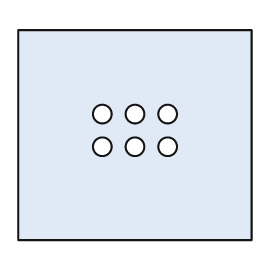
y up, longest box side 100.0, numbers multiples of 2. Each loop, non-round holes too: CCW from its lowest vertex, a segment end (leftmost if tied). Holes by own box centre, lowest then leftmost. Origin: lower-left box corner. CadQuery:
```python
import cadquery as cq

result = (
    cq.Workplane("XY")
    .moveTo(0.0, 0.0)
    .lineTo(100.0, 0.0)
    .lineTo(100.0, 90.0)
    .lineTo(0.0, 90.0)
    .close()
    .moveTo(36.0, 40.0)
    .circle(4.0)
    .moveTo(50.0, 40.0)
    .circle(4.0)
    .moveTo(64.0, 40.0)
    .circle(4.0)
    .moveTo(36.0, 54.0)
    .circle(4.0)
    .moveTo(50.0, 54.0)
    .circle(4.0)
    .moveTo(64.0, 54.0)
    .circle(4.0)
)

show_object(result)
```